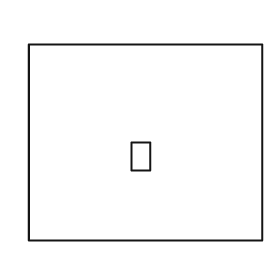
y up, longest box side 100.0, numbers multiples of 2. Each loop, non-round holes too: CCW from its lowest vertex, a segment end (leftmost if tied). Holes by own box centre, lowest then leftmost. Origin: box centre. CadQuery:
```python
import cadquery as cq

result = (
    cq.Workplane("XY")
    .moveTo(-50.0, -42.0)
    .lineTo(50.0, -42.0)
    .lineTo(50.0, 42.0)
    .lineTo(-50.0, 42.0)
    .close()
    .moveTo(-6.0, -12.0)
    .lineTo(2.0, -12.0)
    .lineTo(2.0, 0.0)
    .lineTo(-6.0, 0.0)
    .close()
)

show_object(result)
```